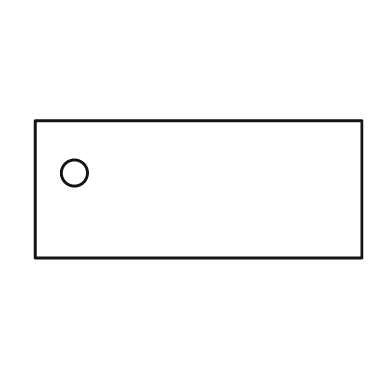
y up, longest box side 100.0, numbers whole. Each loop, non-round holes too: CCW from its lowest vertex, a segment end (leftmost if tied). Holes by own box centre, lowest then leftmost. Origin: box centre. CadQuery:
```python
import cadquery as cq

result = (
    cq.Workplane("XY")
    .moveTo(-50.0, -21.0)
    .lineTo(50.0, -21.0)
    .lineTo(50.0, 21.0)
    .lineTo(-50.0, 21.0)
    .close()
    .moveTo(-38.0, 5.0)
    .circle(4.0)
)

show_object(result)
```